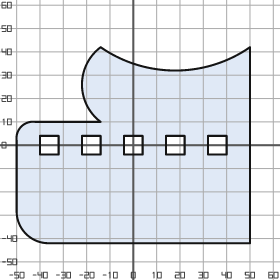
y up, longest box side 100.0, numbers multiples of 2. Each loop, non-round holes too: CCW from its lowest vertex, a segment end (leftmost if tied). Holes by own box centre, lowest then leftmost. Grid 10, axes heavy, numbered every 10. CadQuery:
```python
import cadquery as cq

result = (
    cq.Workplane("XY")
    .moveTo(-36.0, -42.0)
    .lineTo(50.0, -42.0)
    .lineTo(50.0, 42.0)
    .threePointArc((18.0, 32.0), (-14.0, 42.0))
    .threePointArc((-22.0, 26.0), (-14.0, 10.0))
    .lineTo(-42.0, 10.0)
    .threePointArc((-48.0, 8.0), (-50.0, 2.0))
    .lineTo(-50.0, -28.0)
    .threePointArc((-46.0, -38.0), (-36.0, -42.0))
    .close()
    .moveTo(-40.0, -4.0)
    .lineTo(-32.0, -4.0)
    .lineTo(-32.0, 4.0)
    .lineTo(-40.0, 4.0)
    .close()
    .moveTo(-22.0, -4.0)
    .lineTo(-14.0, -4.0)
    .lineTo(-14.0, 4.0)
    .lineTo(-22.0, 4.0)
    .close()
    .moveTo(-4.0, -4.0)
    .lineTo(4.0, -4.0)
    .lineTo(4.0, 4.0)
    .lineTo(-4.0, 4.0)
    .close()
    .moveTo(14.0, -4.0)
    .lineTo(22.0, -4.0)
    .lineTo(22.0, 4.0)
    .lineTo(14.0, 4.0)
    .close()
    .moveTo(32.0, -4.0)
    .lineTo(40.0, -4.0)
    .lineTo(40.0, 4.0)
    .lineTo(32.0, 4.0)
    .close()
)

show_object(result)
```